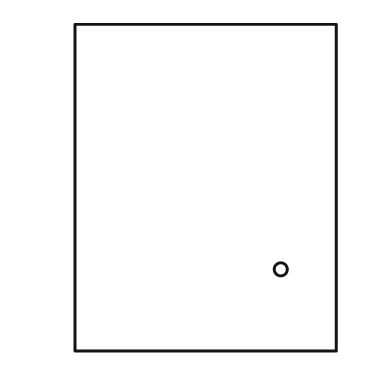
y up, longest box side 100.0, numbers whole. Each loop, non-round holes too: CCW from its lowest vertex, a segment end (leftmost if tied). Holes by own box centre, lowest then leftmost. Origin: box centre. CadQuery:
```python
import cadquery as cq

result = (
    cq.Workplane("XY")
    .moveTo(-40.0, -50.0)
    .lineTo(40.0, -50.0)
    .lineTo(40.0, 50.0)
    .lineTo(-40.0, 50.0)
    .close()
    .moveTo(23.0, -25.0)
    .circle(2.0)
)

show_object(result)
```